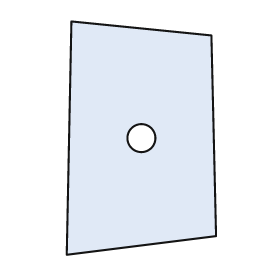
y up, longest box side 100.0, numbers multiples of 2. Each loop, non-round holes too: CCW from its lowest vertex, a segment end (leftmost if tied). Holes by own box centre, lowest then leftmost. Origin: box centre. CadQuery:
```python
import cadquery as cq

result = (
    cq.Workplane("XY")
    .moveTo(-32.0, -50.0)
    .lineTo(32.0, -42.0)
    .lineTo(30.0, 44.0)
    .lineTo(-30.0, 50.0)
    .close()
    .moveTo(0.0, 0.0)
    .circle(6.0)
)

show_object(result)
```